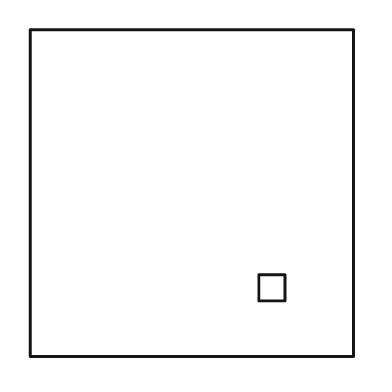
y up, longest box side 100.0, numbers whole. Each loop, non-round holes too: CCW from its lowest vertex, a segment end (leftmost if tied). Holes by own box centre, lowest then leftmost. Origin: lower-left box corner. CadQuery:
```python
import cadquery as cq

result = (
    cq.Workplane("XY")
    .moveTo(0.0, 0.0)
    .lineTo(99.0, 0.0)
    .lineTo(99.0, 100.0)
    .lineTo(0.0, 100.0)
    .close()
    .moveTo(70.0, 17.0)
    .lineTo(78.0, 17.0)
    .lineTo(78.0, 25.0)
    .lineTo(70.0, 25.0)
    .close()
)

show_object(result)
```